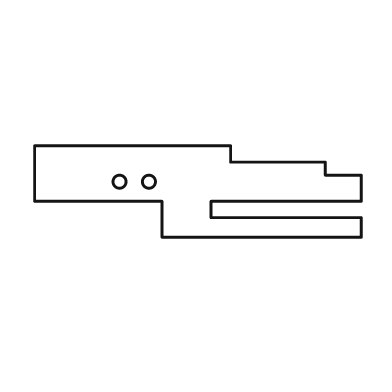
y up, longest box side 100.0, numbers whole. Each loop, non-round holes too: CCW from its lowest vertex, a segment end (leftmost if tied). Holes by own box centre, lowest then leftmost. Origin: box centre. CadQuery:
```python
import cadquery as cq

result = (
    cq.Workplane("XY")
    .moveTo(-11.0, -14.0)
    .lineTo(50.0, -14.0)
    .lineTo(50.0, -8.0)
    .lineTo(4.0, -8.0)
    .lineTo(4.0, -3.0)
    .lineTo(50.0, -3.0)
    .lineTo(50.0, 5.0)
    .lineTo(39.0, 5.0)
    .lineTo(39.0, 9.0)
    .lineTo(10.0, 9.0)
    .lineTo(10.0, 14.0)
    .lineTo(-50.0, 14.0)
    .lineTo(-50.0, -3.0)
    .lineTo(-11.0, -3.0)
    .close()
    .moveTo(-24.0, 3.0)
    .circle(2.0)
    .moveTo(-15.0, 3.0)
    .circle(2.0)
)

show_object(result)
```